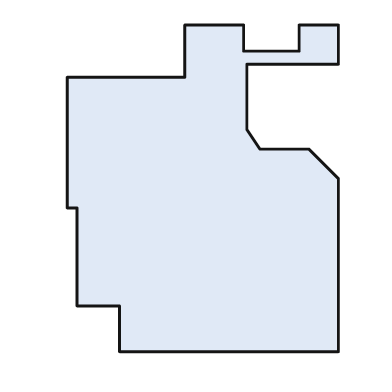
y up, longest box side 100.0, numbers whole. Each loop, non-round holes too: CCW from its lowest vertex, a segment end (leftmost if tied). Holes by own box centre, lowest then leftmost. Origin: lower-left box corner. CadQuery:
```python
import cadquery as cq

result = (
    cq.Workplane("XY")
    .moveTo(16.0, 0.0)
    .lineTo(83.0, 0.0)
    .lineTo(83.0, 53.0)
    .lineTo(74.0, 62.0)
    .lineTo(59.0, 62.0)
    .lineTo(55.0, 68.0)
    .lineTo(55.0, 88.0)
    .lineTo(83.0, 88.0)
    .lineTo(83.0, 100.0)
    .lineTo(71.0, 100.0)
    .lineTo(71.0, 92.0)
    .lineTo(54.0, 92.0)
    .lineTo(54.0, 100.0)
    .lineTo(36.0, 100.0)
    .lineTo(36.0, 84.0)
    .lineTo(0.0, 84.0)
    .lineTo(0.0, 44.0)
    .lineTo(3.0, 44.0)
    .lineTo(3.0, 14.0)
    .lineTo(16.0, 14.0)
    .close()
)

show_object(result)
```